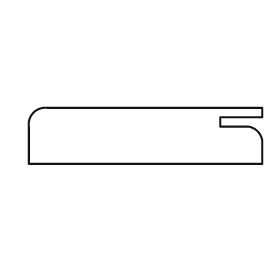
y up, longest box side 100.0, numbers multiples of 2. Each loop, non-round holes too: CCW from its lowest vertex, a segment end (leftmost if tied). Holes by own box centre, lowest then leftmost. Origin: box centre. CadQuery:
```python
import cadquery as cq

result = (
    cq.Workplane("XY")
    .moveTo(-50.0, -12.0)
    .lineTo(50.0, -12.0)
    .lineTo(50.0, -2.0)
    .threePointArc((48.0, 2.0), (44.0, 4.0))
    .lineTo(32.0, 4.0)
    .lineTo(32.0, 8.0)
    .lineTo(50.0, 8.0)
    .lineTo(50.0, 12.0)
    .lineTo(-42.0, 12.0)
    .threePointArc((-48.0, 10.0), (-50.0, 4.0))
    .close()
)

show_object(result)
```